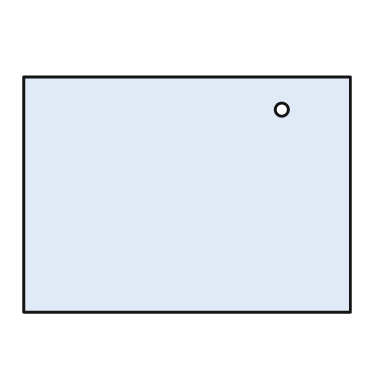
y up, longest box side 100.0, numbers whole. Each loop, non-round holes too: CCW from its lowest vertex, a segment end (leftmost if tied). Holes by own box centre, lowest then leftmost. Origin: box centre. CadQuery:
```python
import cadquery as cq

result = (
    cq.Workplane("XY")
    .moveTo(-50.0, -36.0)
    .lineTo(50.0, -36.0)
    .lineTo(50.0, 36.0)
    .lineTo(-50.0, 36.0)
    .close()
    .moveTo(29.0, 26.0)
    .circle(2.0)
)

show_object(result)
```